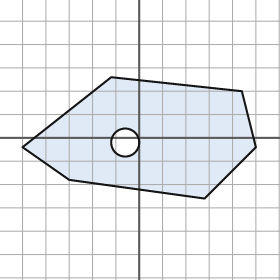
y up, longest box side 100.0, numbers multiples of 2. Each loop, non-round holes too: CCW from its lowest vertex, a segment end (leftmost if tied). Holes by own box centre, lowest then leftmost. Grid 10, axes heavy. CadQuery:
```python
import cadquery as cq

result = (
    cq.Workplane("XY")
    .moveTo(28.0, -26.0)
    .lineTo(50.0, -4.0)
    .lineTo(44.0, 20.0)
    .lineTo(-12.0, 26.0)
    .lineTo(-50.0, -4.0)
    .lineTo(-30.0, -18.0)
    .close()
    .moveTo(-6.0, -2.0)
    .circle(6.0)
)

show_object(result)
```